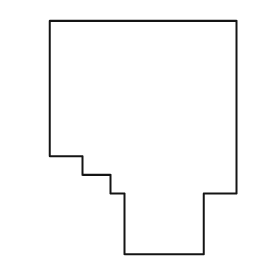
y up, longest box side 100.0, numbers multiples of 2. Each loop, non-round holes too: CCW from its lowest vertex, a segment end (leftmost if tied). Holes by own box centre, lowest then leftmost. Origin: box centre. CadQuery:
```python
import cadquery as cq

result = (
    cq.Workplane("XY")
    .moveTo(-8.0, -50.0)
    .lineTo(26.0, -50.0)
    .lineTo(26.0, -24.0)
    .lineTo(40.0, -24.0)
    .lineTo(40.0, 50.0)
    .lineTo(-40.0, 50.0)
    .lineTo(-40.0, -8.0)
    .lineTo(-26.0, -8.0)
    .lineTo(-26.0, -16.0)
    .lineTo(-14.0, -16.0)
    .lineTo(-14.0, -24.0)
    .lineTo(-8.0, -24.0)
    .close()
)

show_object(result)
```